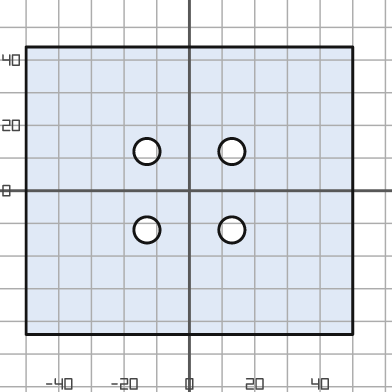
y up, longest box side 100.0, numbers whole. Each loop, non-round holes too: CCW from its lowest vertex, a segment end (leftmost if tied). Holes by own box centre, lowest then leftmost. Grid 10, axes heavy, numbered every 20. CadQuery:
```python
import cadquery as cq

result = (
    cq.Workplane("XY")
    .moveTo(-50.0, -44.0)
    .lineTo(50.0, -44.0)
    .lineTo(50.0, 44.0)
    .lineTo(-50.0, 44.0)
    .close()
    .moveTo(-13.0, -12.0)
    .circle(4.0)
    .moveTo(13.0, -12.0)
    .circle(4.0)
    .moveTo(-13.0, 12.0)
    .circle(4.0)
    .moveTo(13.0, 12.0)
    .circle(4.0)
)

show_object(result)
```